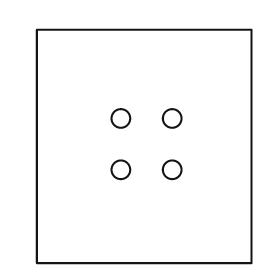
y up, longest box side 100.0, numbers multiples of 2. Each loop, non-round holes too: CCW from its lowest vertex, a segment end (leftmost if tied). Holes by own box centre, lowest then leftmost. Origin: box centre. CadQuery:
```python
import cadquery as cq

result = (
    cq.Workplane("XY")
    .moveTo(-46.0, -50.0)
    .lineTo(46.0, -50.0)
    .lineTo(46.0, 50.0)
    .lineTo(-46.0, 50.0)
    .close()
    .moveTo(-10.0, -10.0)
    .circle(4.0)
    .moveTo(12.0, -10.0)
    .circle(4.0)
    .moveTo(-10.0, 12.0)
    .circle(4.0)
    .moveTo(12.0, 12.0)
    .circle(4.0)
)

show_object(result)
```